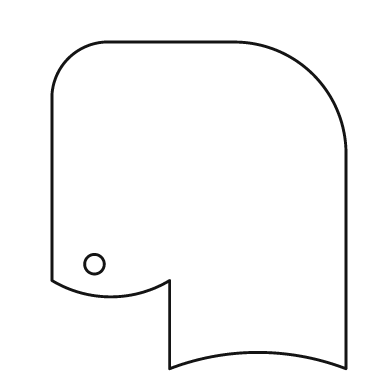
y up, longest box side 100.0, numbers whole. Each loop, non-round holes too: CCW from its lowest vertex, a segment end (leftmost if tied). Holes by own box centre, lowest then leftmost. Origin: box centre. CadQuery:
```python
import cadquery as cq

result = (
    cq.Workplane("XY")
    .moveTo(-9.0, -50.0)
    .threePointArc((18.0, -45.0), (45.0, -50.0))
    .lineTo(45.0, 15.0)
    .threePointArc((35.0, 40.0), (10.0, 50.0))
    .lineTo(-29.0, 50.0)
    .threePointArc((-40.0, 45.0), (-45.0, 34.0))
    .lineTo(-45.0, -23.0)
    .threePointArc((-27.0, -28.0), (-9.0, -23.0))
    .close()
    .moveTo(-32.0, -18.0)
    .circle(3.0)
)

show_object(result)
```